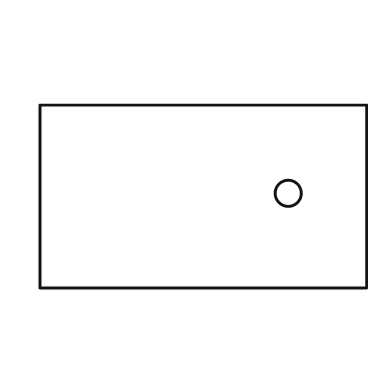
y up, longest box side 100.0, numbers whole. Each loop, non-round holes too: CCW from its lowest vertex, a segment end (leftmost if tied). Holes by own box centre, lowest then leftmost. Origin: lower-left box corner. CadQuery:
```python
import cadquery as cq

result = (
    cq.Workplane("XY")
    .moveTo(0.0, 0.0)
    .lineTo(100.0, 0.0)
    .lineTo(100.0, 56.0)
    .lineTo(0.0, 56.0)
    .close()
    .moveTo(76.0, 29.0)
    .circle(4.0)
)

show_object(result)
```